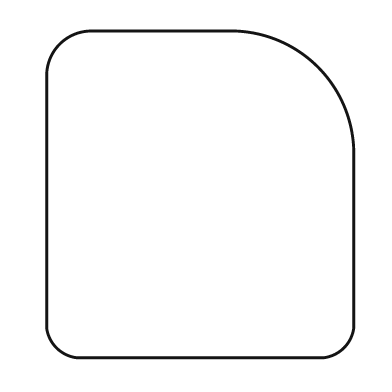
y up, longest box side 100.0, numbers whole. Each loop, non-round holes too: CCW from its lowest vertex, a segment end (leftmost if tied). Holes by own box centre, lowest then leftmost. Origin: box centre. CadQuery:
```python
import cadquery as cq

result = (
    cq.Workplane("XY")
    .moveTo(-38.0, -50.0)
    .lineTo(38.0, -50.0)
    .threePointArc((44.0, -47.0), (47.0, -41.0))
    .lineTo(47.0, 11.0)
    .threePointArc((36.0, 39.0), (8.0, 50.0))
    .lineTo(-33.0, 50.0)
    .threePointArc((-43.0, 46.0), (-47.0, 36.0))
    .lineTo(-47.0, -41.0)
    .threePointArc((-44.0, -47.0), (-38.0, -50.0))
    .close()
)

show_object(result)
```